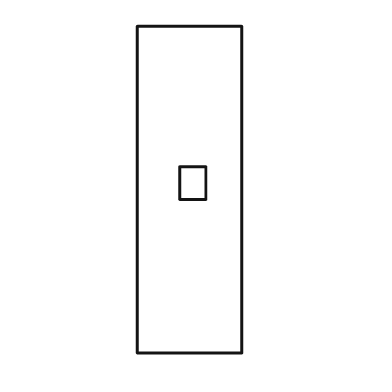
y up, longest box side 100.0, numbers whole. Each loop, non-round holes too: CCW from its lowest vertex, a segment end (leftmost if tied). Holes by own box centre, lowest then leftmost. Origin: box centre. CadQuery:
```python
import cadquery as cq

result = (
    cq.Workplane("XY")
    .moveTo(-16.0, -50.0)
    .lineTo(16.0, -50.0)
    .lineTo(16.0, 50.0)
    .lineTo(-16.0, 50.0)
    .close()
    .moveTo(-3.0, -3.0)
    .lineTo(5.0, -3.0)
    .lineTo(5.0, 7.0)
    .lineTo(-3.0, 7.0)
    .close()
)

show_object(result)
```